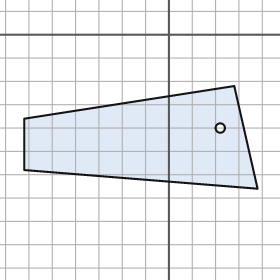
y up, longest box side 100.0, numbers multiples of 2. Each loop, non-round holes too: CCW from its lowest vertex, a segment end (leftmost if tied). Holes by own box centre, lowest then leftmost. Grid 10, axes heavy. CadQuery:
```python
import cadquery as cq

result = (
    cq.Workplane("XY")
    .moveTo(38.0, -66.0)
    .lineTo(28.0, -22.0)
    .lineTo(-62.0, -36.0)
    .lineTo(-62.0, -58.0)
    .close()
    .moveTo(22.0, -40.0)
    .circle(2.0)
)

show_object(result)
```